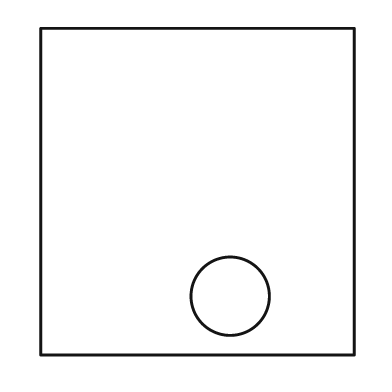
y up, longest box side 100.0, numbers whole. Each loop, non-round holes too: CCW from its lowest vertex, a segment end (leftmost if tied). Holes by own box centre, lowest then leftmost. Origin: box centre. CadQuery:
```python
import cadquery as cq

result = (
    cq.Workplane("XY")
    .moveTo(-48.0, -50.0)
    .lineTo(48.0, -50.0)
    .lineTo(48.0, 50.0)
    .lineTo(-48.0, 50.0)
    .close()
    .moveTo(10.0, -32.0)
    .circle(12.0)
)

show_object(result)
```